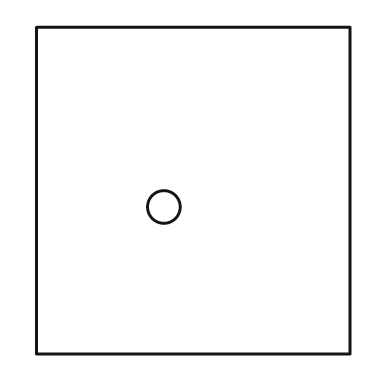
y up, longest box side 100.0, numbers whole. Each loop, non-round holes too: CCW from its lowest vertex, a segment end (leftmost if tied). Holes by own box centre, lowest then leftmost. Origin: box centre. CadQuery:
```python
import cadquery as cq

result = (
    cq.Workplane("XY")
    .moveTo(-48.0, -50.0)
    .lineTo(48.0, -50.0)
    .lineTo(48.0, 50.0)
    .lineTo(-48.0, 50.0)
    .close()
    .moveTo(-9.0, -5.0)
    .circle(5.0)
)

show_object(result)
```